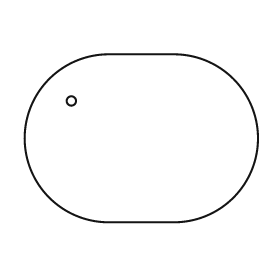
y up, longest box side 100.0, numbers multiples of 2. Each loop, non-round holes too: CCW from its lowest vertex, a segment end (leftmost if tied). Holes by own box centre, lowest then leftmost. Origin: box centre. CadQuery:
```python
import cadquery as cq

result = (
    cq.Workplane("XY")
    .moveTo(-14.0, -36.0)
    .lineTo(14.0, -36.0)
    .threePointArc((50.0, 0.0), (14.0, 36.0))
    .lineTo(-14.0, 36.0)
    .threePointArc((-50.0, 0.0), (-14.0, -36.0))
    .close()
    .moveTo(-30.0, 16.0)
    .circle(2.0)
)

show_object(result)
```